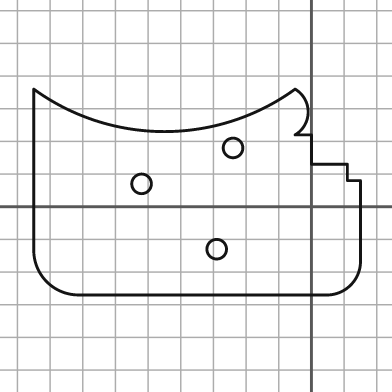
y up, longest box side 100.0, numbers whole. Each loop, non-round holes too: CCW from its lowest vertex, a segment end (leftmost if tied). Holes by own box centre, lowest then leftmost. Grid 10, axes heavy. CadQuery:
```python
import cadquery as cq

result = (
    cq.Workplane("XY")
    .moveTo(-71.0, -27.0)
    .lineTo(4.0, -27.0)
    .threePointArc((12.0, -24.0), (15.0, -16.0))
    .lineTo(15.0, 8.0)
    .lineTo(11.0, 8.0)
    .lineTo(11.0, 13.0)
    .lineTo(0.0, 13.0)
    .lineTo(0.0, 22.0)
    .lineTo(-5.0, 22.0)
    .threePointArc((-1.0, 29.0), (-5.0, 36.0))
    .threePointArc((-45.0, 23.0), (-85.0, 36.0))
    .lineTo(-85.0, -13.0)
    .threePointArc((-81.0, -23.0), (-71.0, -27.0))
    .close()
    .moveTo(-29.0, -13.0)
    .circle(3.0)
    .moveTo(-52.0, 7.0)
    .circle(3.0)
    .moveTo(-24.0, 18.0)
    .circle(3.0)
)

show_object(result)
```